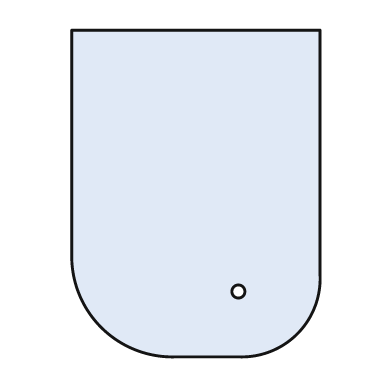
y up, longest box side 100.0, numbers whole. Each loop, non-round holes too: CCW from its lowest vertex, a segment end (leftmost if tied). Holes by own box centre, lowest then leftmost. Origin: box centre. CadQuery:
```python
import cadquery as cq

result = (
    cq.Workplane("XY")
    .moveTo(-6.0, -50.0)
    .lineTo(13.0, -50.0)
    .threePointArc((31.0, -43.0), (38.0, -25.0))
    .lineTo(38.0, 50.0)
    .lineTo(-38.0, 50.0)
    .lineTo(-38.0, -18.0)
    .threePointArc((-29.0, -41.0), (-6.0, -50.0))
    .close()
    .moveTo(13.0, -30.0)
    .circle(2.0)
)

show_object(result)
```